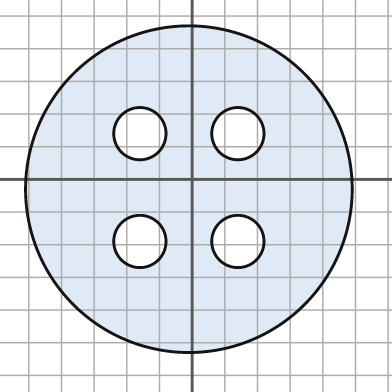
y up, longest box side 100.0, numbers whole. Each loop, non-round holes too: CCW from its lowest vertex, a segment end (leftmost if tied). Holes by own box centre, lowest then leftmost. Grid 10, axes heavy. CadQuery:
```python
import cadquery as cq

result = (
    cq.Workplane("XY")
    .moveTo(-1.0, -3.0)
    .circle(50.0)
    .moveTo(-16.0, -19.0)
    .circle(8.0)
    .moveTo(14.0, -19.0)
    .circle(8.0)
    .moveTo(-16.0, 14.0)
    .circle(8.0)
    .moveTo(14.0, 14.0)
    .circle(8.0)
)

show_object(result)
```